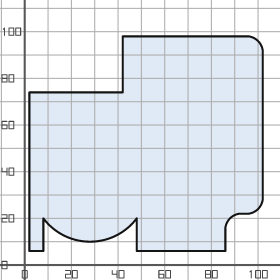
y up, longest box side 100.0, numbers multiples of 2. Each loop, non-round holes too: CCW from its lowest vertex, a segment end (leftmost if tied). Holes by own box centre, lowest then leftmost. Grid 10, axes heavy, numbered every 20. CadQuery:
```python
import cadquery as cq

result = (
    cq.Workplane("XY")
    .moveTo(2.0, 6.0)
    .lineTo(8.0, 6.0)
    .lineTo(8.0, 20.0)
    .threePointArc((28.0, 10.0), (48.0, 20.0))
    .lineTo(48.0, 6.0)
    .lineTo(86.0, 6.0)
    .lineTo(86.0, 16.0)
    .threePointArc((88.0, 20.0), (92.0, 22.0))
    .lineTo(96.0, 22.0)
    .threePointArc((100.0, 24.0), (102.0, 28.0))
    .lineTo(102.0, 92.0)
    .threePointArc((100.0, 96.0), (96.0, 98.0))
    .lineTo(42.0, 98.0)
    .lineTo(42.0, 74.0)
    .lineTo(2.0, 74.0)
    .close()
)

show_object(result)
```